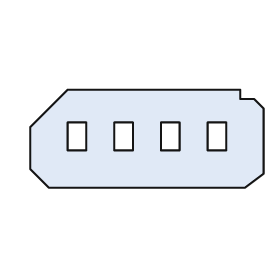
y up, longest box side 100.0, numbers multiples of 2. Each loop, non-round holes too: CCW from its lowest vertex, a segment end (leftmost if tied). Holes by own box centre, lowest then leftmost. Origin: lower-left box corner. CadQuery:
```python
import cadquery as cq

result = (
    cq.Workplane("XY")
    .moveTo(8.0, 0.0)
    .lineTo(92.0, 0.0)
    .lineTo(100.0, 6.0)
    .lineTo(100.0, 34.0)
    .lineTo(96.0, 38.0)
    .lineTo(90.0, 38.0)
    .lineTo(90.0, 42.0)
    .lineTo(16.0, 42.0)
    .lineTo(0.0, 26.0)
    .lineTo(0.0, 8.0)
    .close()
    .moveTo(16.0, 16.0)
    .lineTo(24.0, 16.0)
    .lineTo(24.0, 28.0)
    .lineTo(16.0, 28.0)
    .close()
    .moveTo(36.0, 16.0)
    .lineTo(44.0, 16.0)
    .lineTo(44.0, 28.0)
    .lineTo(36.0, 28.0)
    .close()
    .moveTo(56.0, 16.0)
    .lineTo(64.0, 16.0)
    .lineTo(64.0, 28.0)
    .lineTo(56.0, 28.0)
    .close()
    .moveTo(76.0, 16.0)
    .lineTo(84.0, 16.0)
    .lineTo(84.0, 28.0)
    .lineTo(76.0, 28.0)
    .close()
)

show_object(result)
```